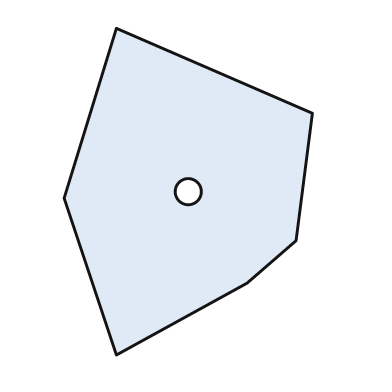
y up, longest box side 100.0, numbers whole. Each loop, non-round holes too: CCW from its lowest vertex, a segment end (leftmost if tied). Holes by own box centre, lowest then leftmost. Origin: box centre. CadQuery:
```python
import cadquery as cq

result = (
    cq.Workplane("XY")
    .moveTo(-22.0, -50.0)
    .lineTo(18.0, -28.0)
    .lineTo(33.0, -15.0)
    .lineTo(38.0, 24.0)
    .lineTo(-22.0, 50.0)
    .lineTo(-38.0, -2.0)
    .close()
    .moveTo(0.0, 0.0)
    .circle(4.0)
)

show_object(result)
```